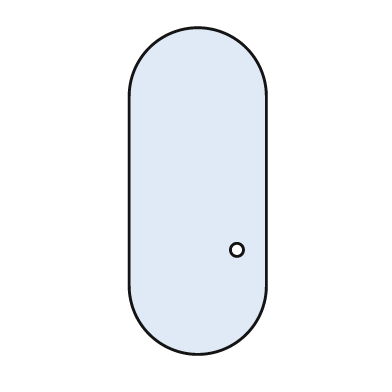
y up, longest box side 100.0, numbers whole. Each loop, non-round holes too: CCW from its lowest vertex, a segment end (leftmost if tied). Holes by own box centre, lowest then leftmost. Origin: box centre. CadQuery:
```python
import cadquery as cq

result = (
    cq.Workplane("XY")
    .moveTo(-21.0, -29.0)
    .threePointArc((0.0, -50.0), (21.0, -29.0))
    .lineTo(21.0, 29.0)
    .threePointArc((0.0, 50.0), (-21.0, 29.0))
    .close()
    .moveTo(12.0, -18.0)
    .circle(2.0)
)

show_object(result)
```